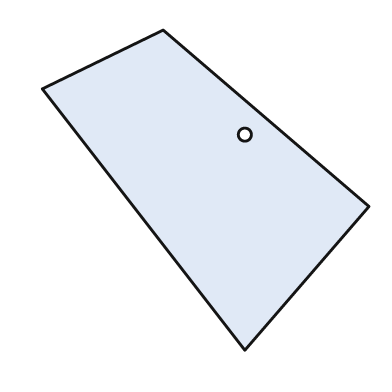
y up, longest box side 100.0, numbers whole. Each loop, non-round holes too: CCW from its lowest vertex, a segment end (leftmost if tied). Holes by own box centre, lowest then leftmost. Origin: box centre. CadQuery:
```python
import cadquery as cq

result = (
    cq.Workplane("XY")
    .moveTo(12.0, -49.0)
    .lineTo(50.0, -5.0)
    .lineTo(-13.0, 49.0)
    .lineTo(-50.0, 31.0)
    .close()
    .moveTo(12.0, 17.0)
    .circle(2.0)
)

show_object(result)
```